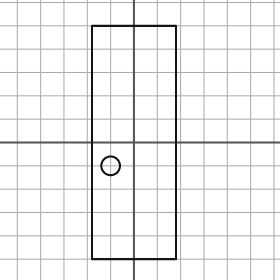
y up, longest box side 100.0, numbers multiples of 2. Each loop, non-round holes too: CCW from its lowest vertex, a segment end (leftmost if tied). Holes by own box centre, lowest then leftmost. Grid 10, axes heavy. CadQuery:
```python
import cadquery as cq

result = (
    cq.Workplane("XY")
    .moveTo(-18.0, -50.0)
    .lineTo(18.0, -50.0)
    .lineTo(18.0, 50.0)
    .lineTo(-18.0, 50.0)
    .close()
    .moveTo(-10.0, -10.0)
    .circle(4.0)
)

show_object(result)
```